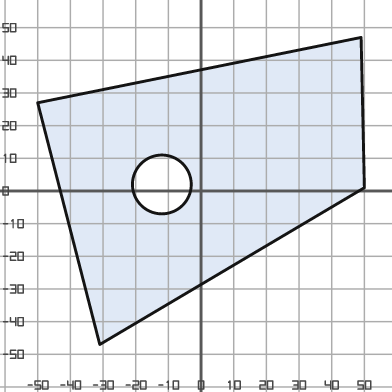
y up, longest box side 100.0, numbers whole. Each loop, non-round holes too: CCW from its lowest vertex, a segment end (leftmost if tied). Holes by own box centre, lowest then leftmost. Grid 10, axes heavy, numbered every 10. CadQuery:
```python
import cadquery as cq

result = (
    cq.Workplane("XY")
    .moveTo(-31.0, -47.0)
    .lineTo(50.0, 1.0)
    .lineTo(49.0, 47.0)
    .lineTo(-50.0, 27.0)
    .close()
    .moveTo(-12.0, 2.0)
    .circle(9.0)
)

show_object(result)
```